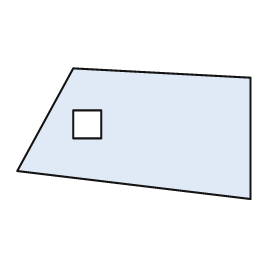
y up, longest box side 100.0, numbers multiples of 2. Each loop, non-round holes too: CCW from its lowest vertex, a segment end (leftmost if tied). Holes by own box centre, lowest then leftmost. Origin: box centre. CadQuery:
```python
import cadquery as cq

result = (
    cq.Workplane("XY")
    .moveTo(50.0, -28.0)
    .lineTo(50.0, 24.0)
    .lineTo(-26.0, 28.0)
    .lineTo(-50.0, -16.0)
    .close()
    .moveTo(-26.0, -2.0)
    .lineTo(-14.0, -2.0)
    .lineTo(-14.0, 10.0)
    .lineTo(-26.0, 10.0)
    .close()
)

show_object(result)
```